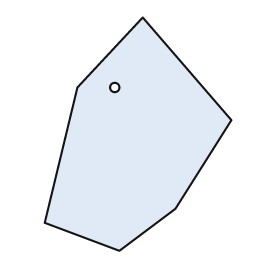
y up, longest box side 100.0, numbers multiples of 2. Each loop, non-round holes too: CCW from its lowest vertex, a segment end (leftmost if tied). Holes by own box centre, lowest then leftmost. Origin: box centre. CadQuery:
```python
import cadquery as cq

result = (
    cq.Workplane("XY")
    .moveTo(-8.0, -50.0)
    .lineTo(16.0, -32.0)
    .lineTo(40.0, 6.0)
    .lineTo(2.0, 50.0)
    .lineTo(-26.0, 20.0)
    .lineTo(-40.0, -38.0)
    .close()
    .moveTo(-10.0, 20.0)
    .circle(2.0)
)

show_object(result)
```